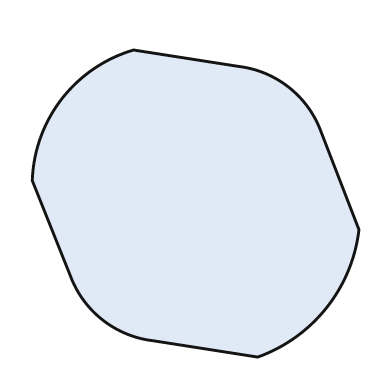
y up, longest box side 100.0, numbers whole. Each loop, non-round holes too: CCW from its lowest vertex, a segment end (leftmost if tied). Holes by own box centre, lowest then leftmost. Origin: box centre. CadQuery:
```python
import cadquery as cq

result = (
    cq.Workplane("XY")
    .moveTo(19.0, -47.0)
    .threePointArc((40.0, -32.0), (50.0, -8.0))
    .lineTo(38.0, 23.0)
    .threePointArc((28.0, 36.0), (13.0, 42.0))
    .lineTo(-19.0, 47.0)
    .threePointArc((-41.0, 32.0), (-50.0, 7.0))
    .lineTo(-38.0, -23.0)
    .threePointArc((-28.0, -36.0), (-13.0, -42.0))
    .close()
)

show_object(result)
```